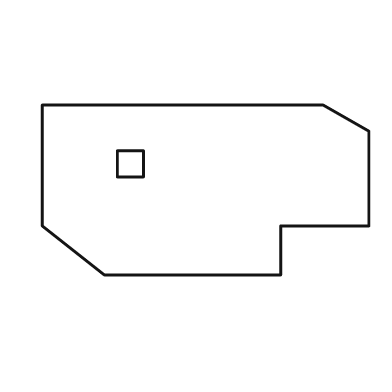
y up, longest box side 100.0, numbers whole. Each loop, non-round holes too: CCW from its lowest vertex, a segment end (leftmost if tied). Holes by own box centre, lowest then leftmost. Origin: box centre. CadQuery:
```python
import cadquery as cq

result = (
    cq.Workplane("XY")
    .moveTo(-31.0, -26.0)
    .lineTo(23.0, -26.0)
    .lineTo(23.0, -11.0)
    .lineTo(50.0, -11.0)
    .lineTo(50.0, 18.0)
    .lineTo(36.0, 26.0)
    .lineTo(-50.0, 26.0)
    .lineTo(-50.0, -11.0)
    .close()
    .moveTo(-27.0, 4.0)
    .lineTo(-19.0, 4.0)
    .lineTo(-19.0, 12.0)
    .lineTo(-27.0, 12.0)
    .close()
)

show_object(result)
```